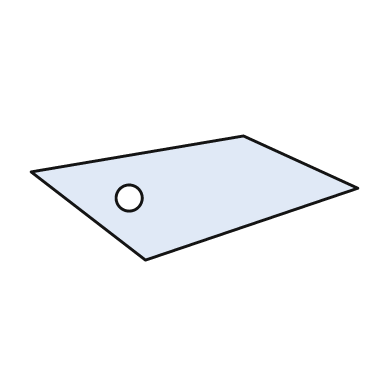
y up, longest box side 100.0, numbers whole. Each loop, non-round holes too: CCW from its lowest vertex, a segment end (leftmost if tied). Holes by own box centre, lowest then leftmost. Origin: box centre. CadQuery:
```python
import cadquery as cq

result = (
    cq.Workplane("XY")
    .moveTo(-15.0, -19.0)
    .lineTo(50.0, 3.0)
    .lineTo(15.0, 19.0)
    .lineTo(-50.0, 8.0)
    .close()
    .moveTo(-20.0, 0.0)
    .circle(4.0)
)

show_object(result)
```